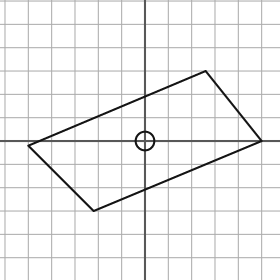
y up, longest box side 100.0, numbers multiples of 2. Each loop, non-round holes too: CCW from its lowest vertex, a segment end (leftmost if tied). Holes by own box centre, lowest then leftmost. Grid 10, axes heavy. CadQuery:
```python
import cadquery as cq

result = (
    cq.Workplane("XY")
    .moveTo(-22.0, -30.0)
    .lineTo(50.0, 0.0)
    .lineTo(26.0, 30.0)
    .lineTo(-50.0, -2.0)
    .close()
    .moveTo(0.0, 0.0)
    .circle(4.0)
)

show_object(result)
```